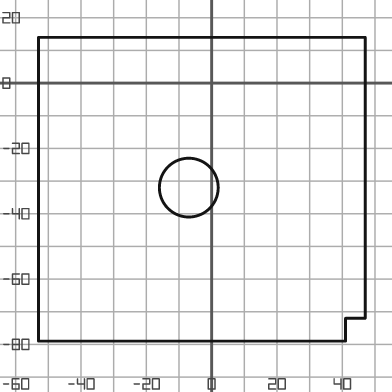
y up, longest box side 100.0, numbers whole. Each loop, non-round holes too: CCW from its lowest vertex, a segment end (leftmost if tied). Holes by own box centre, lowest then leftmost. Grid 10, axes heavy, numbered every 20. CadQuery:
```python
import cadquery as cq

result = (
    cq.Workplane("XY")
    .moveTo(-53.0, -79.0)
    .lineTo(41.0, -79.0)
    .lineTo(41.0, -72.0)
    .lineTo(47.0, -72.0)
    .lineTo(47.0, 14.0)
    .lineTo(-53.0, 14.0)
    .close()
    .moveTo(-7.0, -32.0)
    .circle(9.0)
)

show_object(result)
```